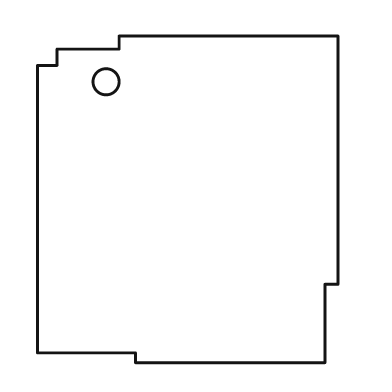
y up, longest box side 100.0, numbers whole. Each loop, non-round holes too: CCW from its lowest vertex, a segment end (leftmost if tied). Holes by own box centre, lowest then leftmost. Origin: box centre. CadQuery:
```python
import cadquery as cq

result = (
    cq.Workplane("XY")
    .moveTo(-16.0, -50.0)
    .lineTo(42.0, -50.0)
    .lineTo(42.0, -26.0)
    .lineTo(46.0, -26.0)
    .lineTo(46.0, 50.0)
    .lineTo(-21.0, 50.0)
    .lineTo(-21.0, 46.0)
    .lineTo(-40.0, 46.0)
    .lineTo(-40.0, 41.0)
    .lineTo(-46.0, 41.0)
    .lineTo(-46.0, -47.0)
    .lineTo(-16.0, -47.0)
    .close()
    .moveTo(-25.0, 36.0)
    .circle(4.0)
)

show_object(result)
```